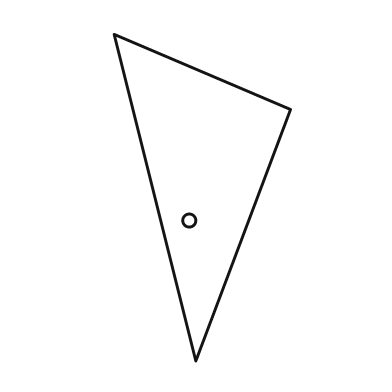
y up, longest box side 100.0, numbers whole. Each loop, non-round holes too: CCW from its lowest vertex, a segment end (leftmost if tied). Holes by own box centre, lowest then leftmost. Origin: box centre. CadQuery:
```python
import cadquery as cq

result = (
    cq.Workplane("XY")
    .moveTo(-2.0, -50.0)
    .lineTo(27.0, 27.0)
    .lineTo(-27.0, 50.0)
    .close()
    .moveTo(-4.0, -7.0)
    .circle(2.0)
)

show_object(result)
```